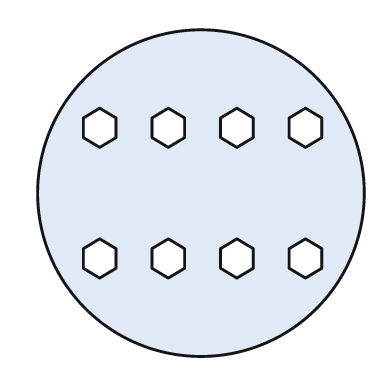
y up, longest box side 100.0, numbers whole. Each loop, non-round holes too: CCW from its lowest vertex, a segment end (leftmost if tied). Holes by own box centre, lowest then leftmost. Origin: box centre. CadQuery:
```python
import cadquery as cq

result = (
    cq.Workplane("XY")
    .moveTo(0.0, 0.0)
    .circle(50.0)
    .moveTo(-31.0, -26.0)
    .lineTo(-26.0, -23.0)
    .lineTo(-26.0, -17.0)
    .lineTo(-31.0, -14.0)
    .lineTo(-36.0, -17.0)
    .lineTo(-36.0, -23.0)
    .close()
    .moveTo(-10.0, -26.0)
    .lineTo(-5.0, -23.0)
    .lineTo(-5.0, -17.0)
    .lineTo(-10.0, -14.0)
    .lineTo(-15.0, -17.0)
    .lineTo(-15.0, -23.0)
    .close()
    .moveTo(11.0, -26.0)
    .lineTo(16.0, -23.0)
    .lineTo(16.0, -17.0)
    .lineTo(11.0, -14.0)
    .lineTo(6.0, -17.0)
    .lineTo(6.0, -23.0)
    .close()
    .moveTo(32.0, -26.0)
    .lineTo(37.0, -23.0)
    .lineTo(37.0, -17.0)
    .lineTo(32.0, -14.0)
    .lineTo(27.0, -17.0)
    .lineTo(27.0, -23.0)
    .close()
    .moveTo(-31.0, 14.0)
    .lineTo(-26.0, 17.0)
    .lineTo(-26.0, 23.0)
    .lineTo(-31.0, 26.0)
    .lineTo(-36.0, 23.0)
    .lineTo(-36.0, 17.0)
    .close()
    .moveTo(-10.0, 14.0)
    .lineTo(-5.0, 17.0)
    .lineTo(-5.0, 23.0)
    .lineTo(-10.0, 26.0)
    .lineTo(-15.0, 23.0)
    .lineTo(-15.0, 17.0)
    .close()
    .moveTo(11.0, 14.0)
    .lineTo(16.0, 17.0)
    .lineTo(16.0, 23.0)
    .lineTo(11.0, 26.0)
    .lineTo(6.0, 23.0)
    .lineTo(6.0, 17.0)
    .close()
    .moveTo(32.0, 14.0)
    .lineTo(37.0, 17.0)
    .lineTo(37.0, 23.0)
    .lineTo(32.0, 26.0)
    .lineTo(27.0, 23.0)
    .lineTo(27.0, 17.0)
    .close()
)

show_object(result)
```